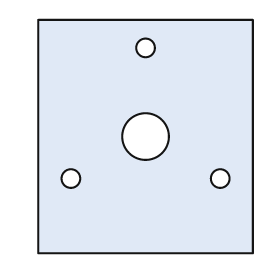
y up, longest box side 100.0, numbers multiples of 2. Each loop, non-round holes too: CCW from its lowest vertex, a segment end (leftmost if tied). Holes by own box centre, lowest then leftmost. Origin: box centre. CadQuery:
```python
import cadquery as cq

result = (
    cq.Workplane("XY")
    .moveTo(-46.0, -50.0)
    .lineTo(46.0, -50.0)
    .lineTo(46.0, 50.0)
    .lineTo(-46.0, 50.0)
    .close()
    .moveTo(-32.0, -18.0)
    .circle(4.0)
    .moveTo(32.0, -18.0)
    .circle(4.0)
    .moveTo(0.0, 0.0)
    .circle(10.0)
    .moveTo(0.0, 38.0)
    .circle(4.0)
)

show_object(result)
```